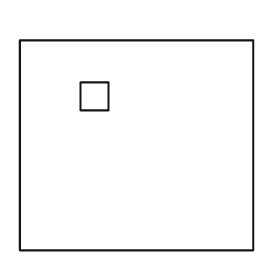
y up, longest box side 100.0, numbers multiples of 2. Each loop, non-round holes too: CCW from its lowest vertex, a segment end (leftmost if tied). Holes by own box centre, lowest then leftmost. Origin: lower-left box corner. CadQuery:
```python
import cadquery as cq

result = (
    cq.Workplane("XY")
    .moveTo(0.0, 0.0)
    .lineTo(100.0, 0.0)
    .lineTo(100.0, 90.0)
    .lineTo(0.0, 90.0)
    .close()
    .moveTo(26.0, 60.0)
    .lineTo(38.0, 60.0)
    .lineTo(38.0, 72.0)
    .lineTo(26.0, 72.0)
    .close()
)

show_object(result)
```